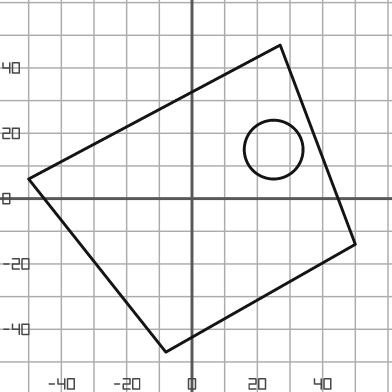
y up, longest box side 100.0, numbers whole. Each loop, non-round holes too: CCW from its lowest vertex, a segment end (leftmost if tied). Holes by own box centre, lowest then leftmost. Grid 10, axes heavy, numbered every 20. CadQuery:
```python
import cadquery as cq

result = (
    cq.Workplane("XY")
    .moveTo(-8.0, -47.0)
    .lineTo(50.0, -14.0)
    .lineTo(27.0, 47.0)
    .lineTo(-50.0, 6.0)
    .close()
    .moveTo(25.0, 15.0)
    .circle(9.0)
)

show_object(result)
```